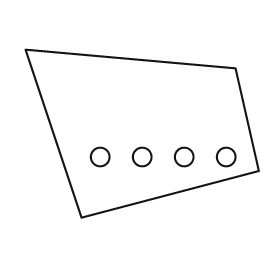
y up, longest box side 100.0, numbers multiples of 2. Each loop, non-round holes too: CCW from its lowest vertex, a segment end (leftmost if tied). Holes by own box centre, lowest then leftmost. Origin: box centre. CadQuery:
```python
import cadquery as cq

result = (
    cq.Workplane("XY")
    .moveTo(-26.0, -36.0)
    .lineTo(50.0, -16.0)
    .lineTo(40.0, 28.0)
    .lineTo(-50.0, 36.0)
    .close()
    .moveTo(-18.0, -10.0)
    .circle(4.0)
    .moveTo(0.0, -10.0)
    .circle(4.0)
    .moveTo(18.0, -10.0)
    .circle(4.0)
    .moveTo(36.0, -10.0)
    .circle(4.0)
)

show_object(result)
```